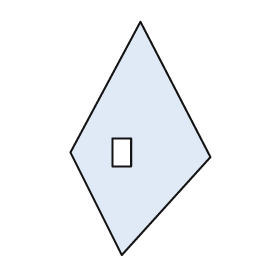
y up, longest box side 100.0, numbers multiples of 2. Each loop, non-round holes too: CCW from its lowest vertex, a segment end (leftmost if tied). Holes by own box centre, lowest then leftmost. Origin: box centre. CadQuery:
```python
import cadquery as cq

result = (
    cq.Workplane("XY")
    .moveTo(-8.0, -50.0)
    .lineTo(30.0, -8.0)
    .lineTo(0.0, 50.0)
    .lineTo(-30.0, -6.0)
    .close()
    .moveTo(-12.0, -12.0)
    .lineTo(-4.0, -12.0)
    .lineTo(-4.0, 0.0)
    .lineTo(-12.0, 0.0)
    .close()
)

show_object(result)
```